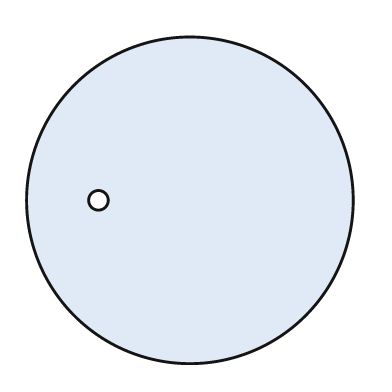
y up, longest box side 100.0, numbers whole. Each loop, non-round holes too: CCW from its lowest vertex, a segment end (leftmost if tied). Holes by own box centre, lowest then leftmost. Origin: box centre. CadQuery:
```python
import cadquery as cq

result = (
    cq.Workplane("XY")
    .moveTo(0.0, 0.0)
    .circle(50.0)
    .moveTo(-28.0, 0.0)
    .circle(3.0)
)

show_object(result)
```